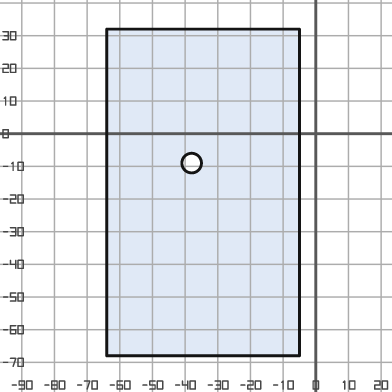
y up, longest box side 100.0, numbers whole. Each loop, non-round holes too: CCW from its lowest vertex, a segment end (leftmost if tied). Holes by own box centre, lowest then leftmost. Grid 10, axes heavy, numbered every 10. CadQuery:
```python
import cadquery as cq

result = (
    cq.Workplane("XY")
    .moveTo(-64.0, -68.0)
    .lineTo(-5.0, -68.0)
    .lineTo(-5.0, 32.0)
    .lineTo(-64.0, 32.0)
    .close()
    .moveTo(-38.0, -9.0)
    .circle(3.0)
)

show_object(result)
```